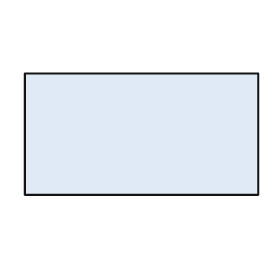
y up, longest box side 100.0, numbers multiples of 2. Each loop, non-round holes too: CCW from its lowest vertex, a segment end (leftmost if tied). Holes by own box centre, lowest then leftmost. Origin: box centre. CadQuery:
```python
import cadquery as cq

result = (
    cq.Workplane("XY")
    .moveTo(-50.0, -26.0)
    .lineTo(50.0, -26.0)
    .lineTo(50.0, 26.0)
    .lineTo(-50.0, 26.0)
    .close()
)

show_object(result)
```